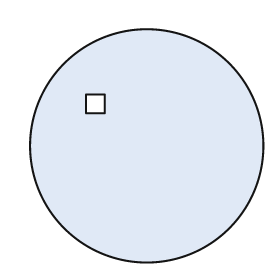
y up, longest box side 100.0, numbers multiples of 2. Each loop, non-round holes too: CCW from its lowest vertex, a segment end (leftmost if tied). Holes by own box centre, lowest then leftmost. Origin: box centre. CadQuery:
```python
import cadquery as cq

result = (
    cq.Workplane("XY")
    .moveTo(0.0, 0.0)
    .circle(50.0)
    .moveTo(-26.0, 14.0)
    .lineTo(-18.0, 14.0)
    .lineTo(-18.0, 22.0)
    .lineTo(-26.0, 22.0)
    .close()
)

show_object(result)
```